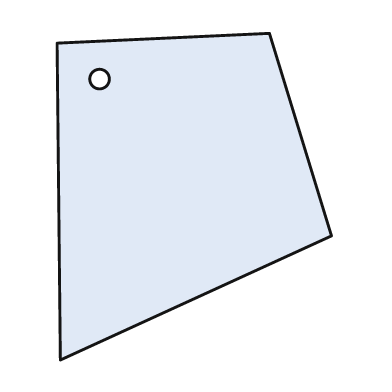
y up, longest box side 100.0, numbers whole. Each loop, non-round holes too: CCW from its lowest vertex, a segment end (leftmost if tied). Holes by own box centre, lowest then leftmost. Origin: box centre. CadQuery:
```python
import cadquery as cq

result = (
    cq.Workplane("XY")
    .moveTo(-41.0, -50.0)
    .lineTo(42.0, -12.0)
    .lineTo(23.0, 50.0)
    .lineTo(-42.0, 47.0)
    .close()
    .moveTo(-29.0, 36.0)
    .circle(3.0)
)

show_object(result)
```